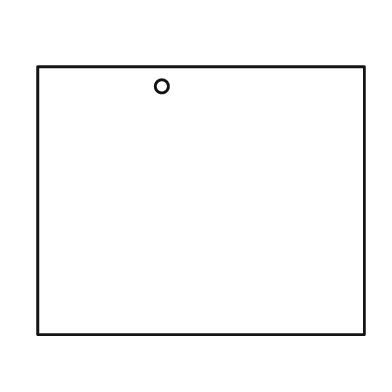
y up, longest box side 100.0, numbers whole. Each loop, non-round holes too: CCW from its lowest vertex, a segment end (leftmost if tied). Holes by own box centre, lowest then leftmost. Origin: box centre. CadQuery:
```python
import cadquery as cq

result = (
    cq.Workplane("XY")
    .moveTo(-50.0, -41.0)
    .lineTo(50.0, -41.0)
    .lineTo(50.0, 41.0)
    .lineTo(-50.0, 41.0)
    .close()
    .moveTo(-12.0, 35.0)
    .circle(2.0)
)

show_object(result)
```